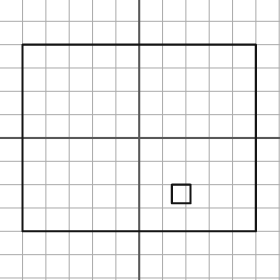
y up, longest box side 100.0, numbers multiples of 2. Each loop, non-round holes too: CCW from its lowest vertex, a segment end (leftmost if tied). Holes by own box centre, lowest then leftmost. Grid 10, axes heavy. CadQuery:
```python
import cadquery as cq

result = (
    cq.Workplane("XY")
    .moveTo(-50.0, -40.0)
    .lineTo(50.0, -40.0)
    .lineTo(50.0, 40.0)
    .lineTo(-50.0, 40.0)
    .close()
    .moveTo(14.0, -28.0)
    .lineTo(22.0, -28.0)
    .lineTo(22.0, -20.0)
    .lineTo(14.0, -20.0)
    .close()
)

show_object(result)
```